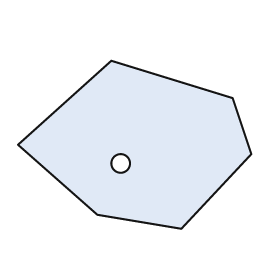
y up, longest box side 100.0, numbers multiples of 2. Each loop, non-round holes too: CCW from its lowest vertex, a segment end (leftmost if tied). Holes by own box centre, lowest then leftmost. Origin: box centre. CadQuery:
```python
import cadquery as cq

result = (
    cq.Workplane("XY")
    .moveTo(20.0, -36.0)
    .lineTo(50.0, -4.0)
    .lineTo(42.0, 20.0)
    .lineTo(-10.0, 36.0)
    .lineTo(-50.0, 0.0)
    .lineTo(-16.0, -30.0)
    .close()
    .moveTo(-6.0, -8.0)
    .circle(4.0)
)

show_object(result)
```